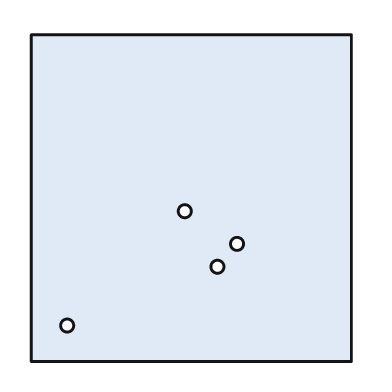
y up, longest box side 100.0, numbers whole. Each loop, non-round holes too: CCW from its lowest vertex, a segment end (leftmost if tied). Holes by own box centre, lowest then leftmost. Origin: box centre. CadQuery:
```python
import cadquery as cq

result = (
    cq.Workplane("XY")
    .moveTo(-49.0, -50.0)
    .lineTo(49.0, -50.0)
    .lineTo(49.0, 50.0)
    .lineTo(-49.0, 50.0)
    .close()
    .moveTo(-38.0, -39.0)
    .circle(2.0)
    .moveTo(8.0, -21.0)
    .circle(2.0)
    .moveTo(14.0, -14.0)
    .circle(2.0)
    .moveTo(-2.0, -4.0)
    .circle(2.0)
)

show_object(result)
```